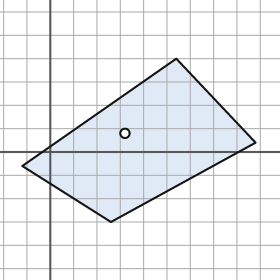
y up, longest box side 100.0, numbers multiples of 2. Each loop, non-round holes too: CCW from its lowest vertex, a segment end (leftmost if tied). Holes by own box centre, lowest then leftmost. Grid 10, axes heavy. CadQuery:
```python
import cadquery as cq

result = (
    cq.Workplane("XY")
    .moveTo(26.0, -30.0)
    .lineTo(88.0, 4.0)
    .lineTo(54.0, 40.0)
    .lineTo(-12.0, -6.0)
    .close()
    .moveTo(32.0, 8.0)
    .circle(2.0)
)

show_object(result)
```